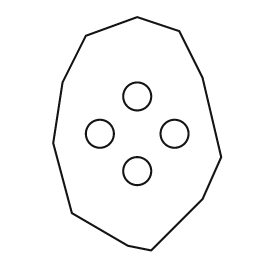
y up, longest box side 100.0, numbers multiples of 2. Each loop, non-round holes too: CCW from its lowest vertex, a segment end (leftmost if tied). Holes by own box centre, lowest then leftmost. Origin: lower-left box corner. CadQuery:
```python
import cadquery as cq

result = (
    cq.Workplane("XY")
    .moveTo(42.0, 0.0)
    .lineTo(64.0, 22.0)
    .lineTo(72.0, 40.0)
    .lineTo(64.0, 74.0)
    .lineTo(54.0, 94.0)
    .lineTo(36.0, 100.0)
    .lineTo(14.0, 92.0)
    .lineTo(4.0, 72.0)
    .lineTo(0.0, 46.0)
    .lineTo(8.0, 16.0)
    .lineTo(32.0, 2.0)
    .close()
    .moveTo(36.0, 34.0)
    .circle(6.0)
    .moveTo(20.0, 50.0)
    .circle(6.0)
    .moveTo(52.0, 50.0)
    .circle(6.0)
    .moveTo(36.0, 66.0)
    .circle(6.0)
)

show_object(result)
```